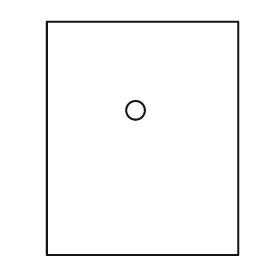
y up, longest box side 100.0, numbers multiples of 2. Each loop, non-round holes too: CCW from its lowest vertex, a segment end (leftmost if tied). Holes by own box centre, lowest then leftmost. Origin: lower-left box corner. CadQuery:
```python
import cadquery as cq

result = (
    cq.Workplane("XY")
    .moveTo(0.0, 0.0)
    .lineTo(82.0, 0.0)
    .lineTo(82.0, 100.0)
    .lineTo(0.0, 100.0)
    .close()
    .moveTo(38.0, 62.0)
    .circle(4.0)
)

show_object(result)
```